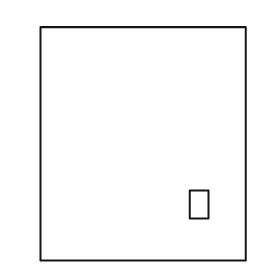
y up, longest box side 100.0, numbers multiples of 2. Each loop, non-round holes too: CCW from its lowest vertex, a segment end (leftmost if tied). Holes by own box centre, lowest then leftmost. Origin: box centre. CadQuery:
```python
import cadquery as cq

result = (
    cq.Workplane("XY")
    .moveTo(-44.0, -50.0)
    .lineTo(44.0, -50.0)
    .lineTo(44.0, 50.0)
    .lineTo(-44.0, 50.0)
    .close()
    .moveTo(20.0, -32.0)
    .lineTo(28.0, -32.0)
    .lineTo(28.0, -20.0)
    .lineTo(20.0, -20.0)
    .close()
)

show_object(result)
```